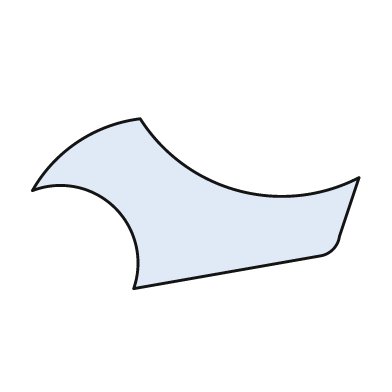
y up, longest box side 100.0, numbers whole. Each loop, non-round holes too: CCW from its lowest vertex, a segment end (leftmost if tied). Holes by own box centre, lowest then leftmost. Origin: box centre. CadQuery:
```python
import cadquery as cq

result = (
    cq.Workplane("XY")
    .moveTo(-19.0, -26.0)
    .lineTo(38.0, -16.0)
    .threePointArc((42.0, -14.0), (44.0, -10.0))
    .lineTo(50.0, 8.0)
    .threePointArc((13.0, 4.0), (-17.0, 26.0))
    .threePointArc((-36.0, 19.0), (-50.0, 4.0))
    .threePointArc((-25.0, -1.0), (-19.0, -26.0))
    .close()
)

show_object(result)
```